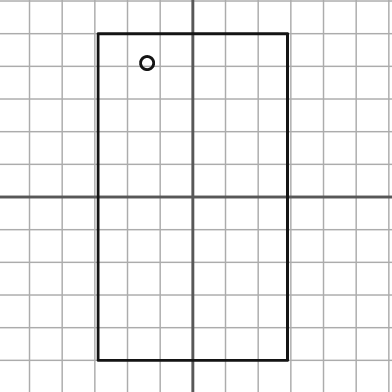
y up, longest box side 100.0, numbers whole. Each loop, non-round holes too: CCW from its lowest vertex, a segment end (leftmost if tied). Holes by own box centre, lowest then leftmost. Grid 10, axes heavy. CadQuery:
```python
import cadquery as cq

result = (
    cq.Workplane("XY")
    .moveTo(-29.0, -50.0)
    .lineTo(29.0, -50.0)
    .lineTo(29.0, 50.0)
    .lineTo(-29.0, 50.0)
    .close()
    .moveTo(-14.0, 41.0)
    .circle(2.0)
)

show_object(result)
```